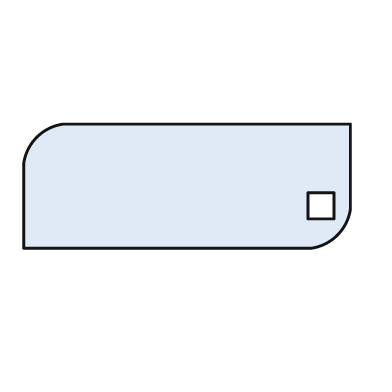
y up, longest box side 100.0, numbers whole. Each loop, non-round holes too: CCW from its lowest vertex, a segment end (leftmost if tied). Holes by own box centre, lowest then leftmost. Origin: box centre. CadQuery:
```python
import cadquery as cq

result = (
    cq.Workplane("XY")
    .moveTo(-50.0, -19.0)
    .lineTo(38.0, -19.0)
    .threePointArc((46.0, -15.0), (50.0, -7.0))
    .lineTo(50.0, 19.0)
    .lineTo(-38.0, 19.0)
    .threePointArc((-46.0, 15.0), (-50.0, 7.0))
    .close()
    .moveTo(37.0, -10.0)
    .lineTo(45.0, -10.0)
    .lineTo(45.0, -2.0)
    .lineTo(37.0, -2.0)
    .close()
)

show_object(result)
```